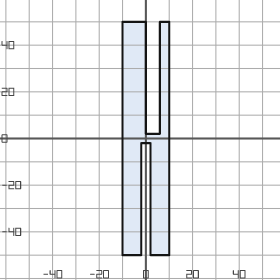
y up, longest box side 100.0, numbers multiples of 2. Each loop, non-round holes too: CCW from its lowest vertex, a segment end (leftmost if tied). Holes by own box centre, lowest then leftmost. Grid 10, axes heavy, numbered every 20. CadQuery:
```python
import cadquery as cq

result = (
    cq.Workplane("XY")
    .moveTo(-10.0, -50.0)
    .lineTo(-2.0, -50.0)
    .lineTo(-2.0, -2.0)
    .lineTo(2.0, -2.0)
    .lineTo(2.0, -50.0)
    .lineTo(10.0, -50.0)
    .lineTo(10.0, 50.0)
    .lineTo(6.0, 50.0)
    .lineTo(6.0, 2.0)
    .lineTo(0.0, 2.0)
    .lineTo(0.0, 50.0)
    .lineTo(-10.0, 50.0)
    .close()
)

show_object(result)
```